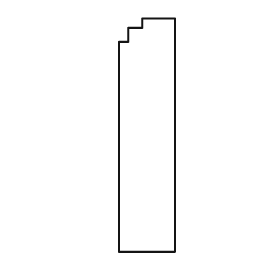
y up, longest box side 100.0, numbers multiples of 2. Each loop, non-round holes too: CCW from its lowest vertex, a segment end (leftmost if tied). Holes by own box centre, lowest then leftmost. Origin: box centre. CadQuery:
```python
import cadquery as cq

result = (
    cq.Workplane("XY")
    .moveTo(-12.0, -50.0)
    .lineTo(12.0, -50.0)
    .lineTo(12.0, 50.0)
    .lineTo(-2.0, 50.0)
    .lineTo(-2.0, 46.0)
    .lineTo(-8.0, 46.0)
    .lineTo(-8.0, 40.0)
    .lineTo(-12.0, 40.0)
    .close()
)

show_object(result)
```